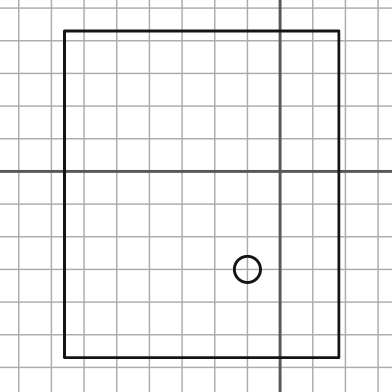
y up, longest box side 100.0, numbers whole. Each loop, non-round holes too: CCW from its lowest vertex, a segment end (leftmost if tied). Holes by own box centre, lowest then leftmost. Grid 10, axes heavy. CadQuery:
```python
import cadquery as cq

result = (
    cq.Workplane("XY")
    .moveTo(-66.0, -57.0)
    .lineTo(18.0, -57.0)
    .lineTo(18.0, 43.0)
    .lineTo(-66.0, 43.0)
    .close()
    .moveTo(-10.0, -30.0)
    .circle(4.0)
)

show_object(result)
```